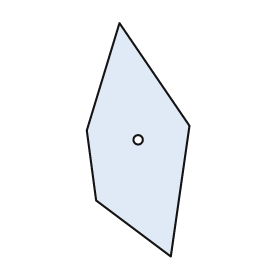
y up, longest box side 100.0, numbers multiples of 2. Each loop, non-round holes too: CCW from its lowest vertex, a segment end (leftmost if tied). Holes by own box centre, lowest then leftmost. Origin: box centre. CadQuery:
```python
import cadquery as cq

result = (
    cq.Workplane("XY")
    .moveTo(14.0, -50.0)
    .lineTo(22.0, 6.0)
    .lineTo(-8.0, 50.0)
    .lineTo(-22.0, 4.0)
    .lineTo(-18.0, -26.0)
    .close()
    .moveTo(0.0, 0.0)
    .circle(2.0)
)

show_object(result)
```